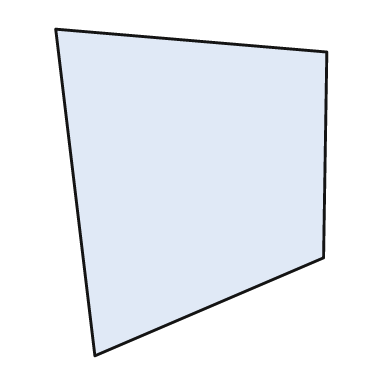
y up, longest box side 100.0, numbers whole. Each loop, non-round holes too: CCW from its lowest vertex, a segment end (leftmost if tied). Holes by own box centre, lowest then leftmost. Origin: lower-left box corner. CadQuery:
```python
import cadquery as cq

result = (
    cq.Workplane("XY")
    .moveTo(12.0, 0.0)
    .lineTo(82.0, 30.0)
    .lineTo(83.0, 93.0)
    .lineTo(0.0, 100.0)
    .close()
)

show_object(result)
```